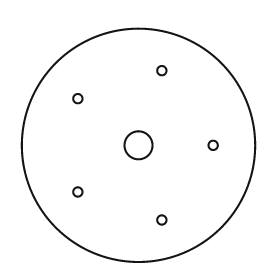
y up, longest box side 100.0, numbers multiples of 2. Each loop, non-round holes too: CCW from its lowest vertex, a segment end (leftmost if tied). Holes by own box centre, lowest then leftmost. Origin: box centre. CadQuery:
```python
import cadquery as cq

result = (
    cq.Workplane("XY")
    .moveTo(0.0, 0.0)
    .circle(50.0)
    .moveTo(10.0, -32.0)
    .circle(2.0)
    .moveTo(-26.0, -20.0)
    .circle(2.0)
    .moveTo(0.0, 0.0)
    .circle(6.0)
    .moveTo(32.0, 0.0)
    .circle(2.0)
    .moveTo(-26.0, 20.0)
    .circle(2.0)
    .moveTo(10.0, 32.0)
    .circle(2.0)
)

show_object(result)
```